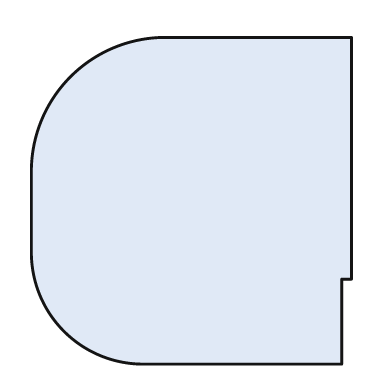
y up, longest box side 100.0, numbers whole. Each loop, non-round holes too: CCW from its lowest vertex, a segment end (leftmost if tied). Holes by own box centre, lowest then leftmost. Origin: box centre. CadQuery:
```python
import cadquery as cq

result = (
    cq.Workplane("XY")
    .moveTo(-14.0, -50.0)
    .lineTo(46.0, -50.0)
    .lineTo(46.0, -24.0)
    .lineTo(49.0, -24.0)
    .lineTo(49.0, 50.0)
    .lineTo(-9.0, 50.0)
    .threePointArc((-37.0, 38.0), (-49.0, 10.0))
    .lineTo(-49.0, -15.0)
    .threePointArc((-39.0, -40.0), (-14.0, -50.0))
    .close()
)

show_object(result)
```